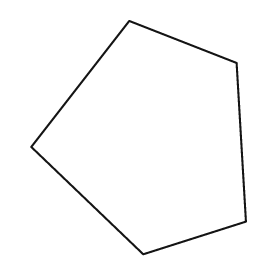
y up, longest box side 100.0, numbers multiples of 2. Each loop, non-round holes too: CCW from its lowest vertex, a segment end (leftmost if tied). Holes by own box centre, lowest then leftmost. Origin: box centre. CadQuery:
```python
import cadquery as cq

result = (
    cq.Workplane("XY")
    .moveTo(2.0, -50.0)
    .lineTo(46.0, -36.0)
    .lineTo(42.0, 32.0)
    .lineTo(-4.0, 50.0)
    .lineTo(-46.0, -4.0)
    .close()
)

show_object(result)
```